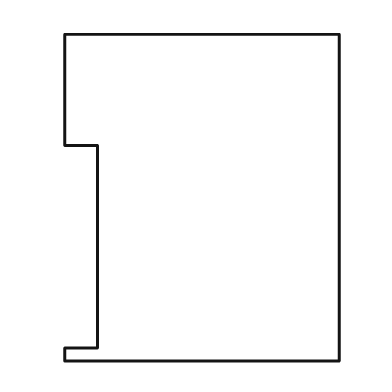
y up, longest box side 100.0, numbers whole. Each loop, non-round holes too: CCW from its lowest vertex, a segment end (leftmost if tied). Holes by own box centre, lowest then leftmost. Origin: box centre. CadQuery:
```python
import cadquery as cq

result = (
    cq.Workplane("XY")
    .moveTo(-42.0, -50.0)
    .lineTo(42.0, -50.0)
    .lineTo(42.0, 50.0)
    .lineTo(-42.0, 50.0)
    .lineTo(-42.0, 16.0)
    .lineTo(-32.0, 16.0)
    .lineTo(-32.0, -46.0)
    .lineTo(-42.0, -46.0)
    .close()
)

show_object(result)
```